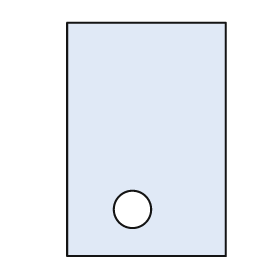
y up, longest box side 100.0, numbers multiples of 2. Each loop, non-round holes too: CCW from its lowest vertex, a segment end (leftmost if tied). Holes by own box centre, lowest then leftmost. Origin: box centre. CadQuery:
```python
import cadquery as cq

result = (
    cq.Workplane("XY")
    .moveTo(-34.0, -50.0)
    .lineTo(34.0, -50.0)
    .lineTo(34.0, 50.0)
    .lineTo(-34.0, 50.0)
    .close()
    .moveTo(-6.0, -30.0)
    .circle(8.0)
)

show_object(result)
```